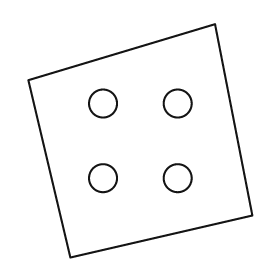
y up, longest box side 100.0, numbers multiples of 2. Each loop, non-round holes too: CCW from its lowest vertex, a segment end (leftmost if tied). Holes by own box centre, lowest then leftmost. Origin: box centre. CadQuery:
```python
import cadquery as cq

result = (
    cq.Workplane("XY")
    .moveTo(-30.0, -50.0)
    .lineTo(48.0, -32.0)
    .lineTo(32.0, 50.0)
    .lineTo(-48.0, 26.0)
    .close()
    .moveTo(-16.0, -16.0)
    .circle(6.0)
    .moveTo(16.0, -16.0)
    .circle(6.0)
    .moveTo(-16.0, 16.0)
    .circle(6.0)
    .moveTo(16.0, 16.0)
    .circle(6.0)
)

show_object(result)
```